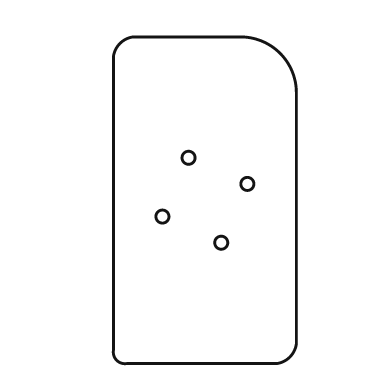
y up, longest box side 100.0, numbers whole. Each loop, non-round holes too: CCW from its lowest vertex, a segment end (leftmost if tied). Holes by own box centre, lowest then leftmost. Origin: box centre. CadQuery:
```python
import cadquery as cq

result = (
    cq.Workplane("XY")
    .moveTo(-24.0, -50.0)
    .lineTo(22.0, -50.0)
    .threePointArc((26.0, -48.0), (28.0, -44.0))
    .lineTo(28.0, 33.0)
    .threePointArc((23.0, 45.0), (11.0, 50.0))
    .lineTo(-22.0, 50.0)
    .threePointArc((-26.0, 48.0), (-28.0, 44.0))
    .lineTo(-28.0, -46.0)
    .threePointArc((-27.0, -49.0), (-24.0, -50.0))
    .close()
    .moveTo(5.0, -13.0)
    .circle(2.0)
    .moveTo(-13.0, -5.0)
    .circle(2.0)
    .moveTo(13.0, 5.0)
    .circle(2.0)
    .moveTo(-5.0, 13.0)
    .circle(2.0)
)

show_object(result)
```